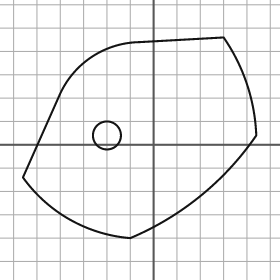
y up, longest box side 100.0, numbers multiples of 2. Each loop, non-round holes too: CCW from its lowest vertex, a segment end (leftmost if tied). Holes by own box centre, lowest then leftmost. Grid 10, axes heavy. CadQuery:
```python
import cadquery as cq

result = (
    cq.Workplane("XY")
    .moveTo(-10.0, -40.0)
    .threePointArc((20.0, -22.0), (44.0, 4.0))
    .threePointArc((40.0, 26.0), (30.0, 46.0))
    .lineTo(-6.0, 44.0)
    .threePointArc((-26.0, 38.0), (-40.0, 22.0))
    .lineTo(-56.0, -14.0)
    .threePointArc((-36.0, -32.0), (-10.0, -40.0))
    .close()
    .moveTo(-20.0, 4.0)
    .circle(6.0)
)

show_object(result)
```